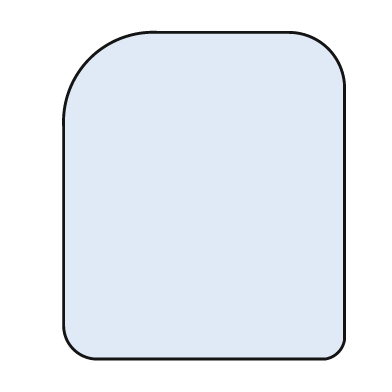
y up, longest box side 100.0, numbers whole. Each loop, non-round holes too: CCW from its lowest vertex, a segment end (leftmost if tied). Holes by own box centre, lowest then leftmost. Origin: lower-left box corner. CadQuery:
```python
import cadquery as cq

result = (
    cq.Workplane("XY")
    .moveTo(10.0, 0.0)
    .lineTo(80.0, 0.0)
    .threePointArc((84.0, 2.0), (86.0, 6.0))
    .lineTo(86.0, 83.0)
    .threePointArc((81.0, 95.0), (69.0, 100.0))
    .lineTo(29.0, 100.0)
    .threePointArc((8.0, 92.0), (0.0, 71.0))
    .lineTo(0.0, 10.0)
    .threePointArc((3.0, 3.0), (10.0, 0.0))
    .close()
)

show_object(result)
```